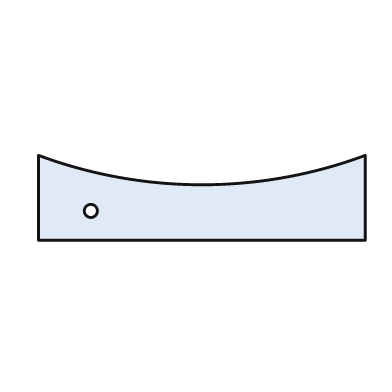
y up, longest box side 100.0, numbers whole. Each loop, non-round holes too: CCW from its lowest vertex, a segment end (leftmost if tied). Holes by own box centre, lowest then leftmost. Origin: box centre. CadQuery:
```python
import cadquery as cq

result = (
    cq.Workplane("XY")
    .moveTo(-50.0, -13.0)
    .lineTo(50.0, -13.0)
    .lineTo(50.0, 13.0)
    .threePointArc((0.0, 4.0), (-50.0, 13.0))
    .close()
    .moveTo(-34.0, -4.0)
    .circle(2.0)
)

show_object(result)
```